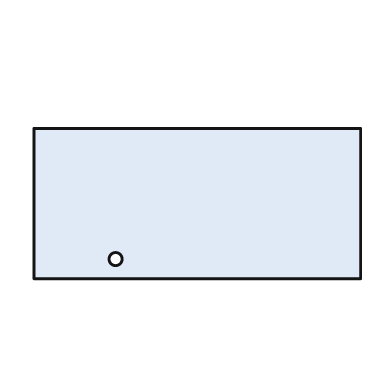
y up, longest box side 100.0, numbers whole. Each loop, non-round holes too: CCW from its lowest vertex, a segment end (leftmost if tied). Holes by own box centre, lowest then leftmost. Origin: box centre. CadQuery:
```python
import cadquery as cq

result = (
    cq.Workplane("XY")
    .moveTo(-50.0, -23.0)
    .lineTo(50.0, -23.0)
    .lineTo(50.0, 23.0)
    .lineTo(-50.0, 23.0)
    .close()
    .moveTo(-25.0, -17.0)
    .circle(2.0)
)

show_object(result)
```